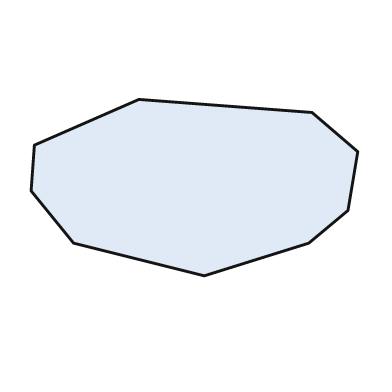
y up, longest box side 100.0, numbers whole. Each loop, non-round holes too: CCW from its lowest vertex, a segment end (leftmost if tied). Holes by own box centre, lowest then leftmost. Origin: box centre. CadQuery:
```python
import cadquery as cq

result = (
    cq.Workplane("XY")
    .moveTo(3.0, -27.0)
    .lineTo(35.0, -17.0)
    .lineTo(47.0, -7.0)
    .lineTo(50.0, 11.0)
    .lineTo(36.0, 23.0)
    .lineTo(-17.0, 27.0)
    .lineTo(-49.0, 13.0)
    .lineTo(-50.0, -1.0)
    .lineTo(-37.0, -17.0)
    .close()
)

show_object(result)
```